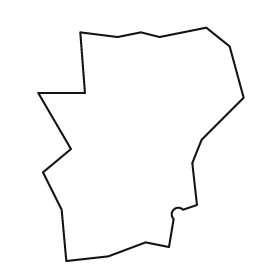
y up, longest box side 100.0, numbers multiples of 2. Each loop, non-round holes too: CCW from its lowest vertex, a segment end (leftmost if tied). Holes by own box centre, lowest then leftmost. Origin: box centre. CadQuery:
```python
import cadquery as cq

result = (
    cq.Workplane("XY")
    .moveTo(-32.0, -50.0)
    .lineTo(-14.0, -48.0)
    .lineTo(2.0, -42.0)
    .lineTo(12.0, -44.0)
    .lineTo(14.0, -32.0)
    .threePointArc((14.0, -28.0), (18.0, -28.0))
    .lineTo(24.0, -26.0)
    .lineTo(22.0, -8.0)
    .lineTo(26.0, 2.0)
    .lineTo(44.0, 20.0)
    .lineTo(38.0, 42.0)
    .lineTo(28.0, 50.0)
    .lineTo(8.0, 46.0)
    .lineTo(0.0, 48.0)
    .lineTo(-10.0, 46.0)
    .lineTo(-26.0, 48.0)
    .lineTo(-24.0, 22.0)
    .lineTo(-44.0, 22.0)
    .lineTo(-30.0, -2.0)
    .lineTo(-42.0, -12.0)
    .lineTo(-34.0, -28.0)
    .close()
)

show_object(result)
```